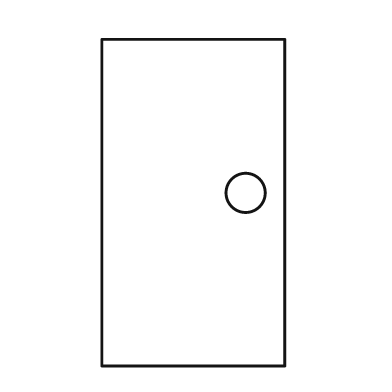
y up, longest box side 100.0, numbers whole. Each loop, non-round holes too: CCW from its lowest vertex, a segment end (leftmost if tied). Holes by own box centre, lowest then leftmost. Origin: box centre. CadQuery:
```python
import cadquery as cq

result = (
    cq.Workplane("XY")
    .moveTo(-28.0, -50.0)
    .lineTo(28.0, -50.0)
    .lineTo(28.0, 50.0)
    .lineTo(-28.0, 50.0)
    .close()
    .moveTo(16.0, 3.0)
    .circle(6.0)
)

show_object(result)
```